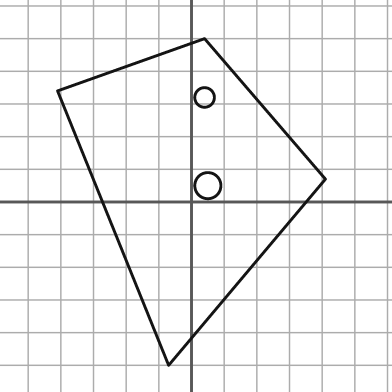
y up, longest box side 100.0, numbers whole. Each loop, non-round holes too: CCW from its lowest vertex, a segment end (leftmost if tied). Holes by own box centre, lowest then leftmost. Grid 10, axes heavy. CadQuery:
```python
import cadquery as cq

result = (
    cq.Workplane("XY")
    .moveTo(-7.0, -50.0)
    .lineTo(41.0, 7.0)
    .lineTo(4.0, 50.0)
    .lineTo(-41.0, 34.0)
    .close()
    .moveTo(5.0, 5.0)
    .circle(4.0)
    .moveTo(4.0, 32.0)
    .circle(3.0)
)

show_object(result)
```